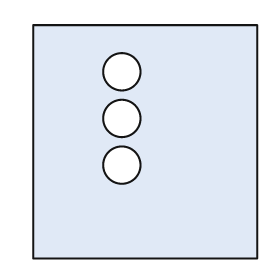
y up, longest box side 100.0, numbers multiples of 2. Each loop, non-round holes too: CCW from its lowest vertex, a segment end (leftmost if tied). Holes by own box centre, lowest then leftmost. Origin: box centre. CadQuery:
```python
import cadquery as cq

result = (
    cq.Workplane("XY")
    .moveTo(-48.0, -50.0)
    .lineTo(48.0, -50.0)
    .lineTo(48.0, 50.0)
    .lineTo(-48.0, 50.0)
    .close()
    .moveTo(-10.0, -10.0)
    .circle(8.0)
    .moveTo(-10.0, 10.0)
    .circle(8.0)
    .moveTo(-10.0, 30.0)
    .circle(8.0)
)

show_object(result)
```